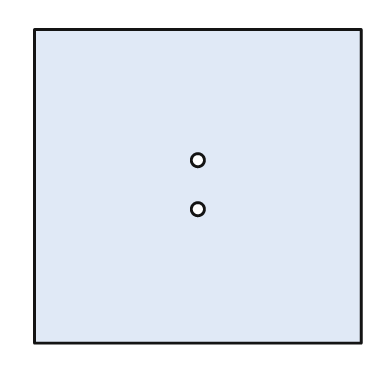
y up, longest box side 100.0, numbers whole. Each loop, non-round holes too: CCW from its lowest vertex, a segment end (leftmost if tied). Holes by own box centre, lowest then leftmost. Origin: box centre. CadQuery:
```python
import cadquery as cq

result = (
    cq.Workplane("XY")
    .moveTo(-50.0, -48.0)
    .lineTo(50.0, -48.0)
    .lineTo(50.0, 48.0)
    .lineTo(-50.0, 48.0)
    .close()
    .moveTo(0.0, -7.0)
    .circle(2.0)
    .moveTo(0.0, 8.0)
    .circle(2.0)
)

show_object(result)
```